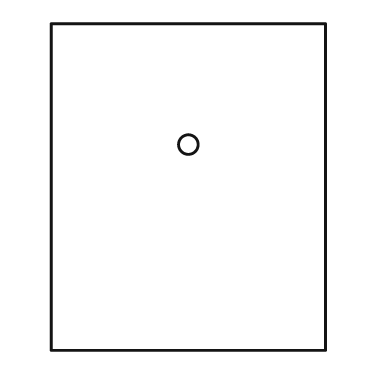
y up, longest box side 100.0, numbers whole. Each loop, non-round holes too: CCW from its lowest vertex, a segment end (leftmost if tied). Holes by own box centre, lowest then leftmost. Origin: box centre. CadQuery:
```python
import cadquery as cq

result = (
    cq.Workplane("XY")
    .moveTo(-42.0, -50.0)
    .lineTo(42.0, -50.0)
    .lineTo(42.0, 50.0)
    .lineTo(-42.0, 50.0)
    .close()
    .moveTo(0.0, 13.0)
    .circle(3.0)
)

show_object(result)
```